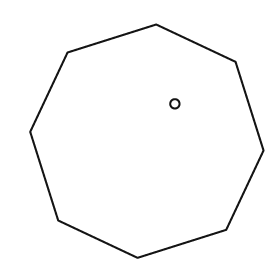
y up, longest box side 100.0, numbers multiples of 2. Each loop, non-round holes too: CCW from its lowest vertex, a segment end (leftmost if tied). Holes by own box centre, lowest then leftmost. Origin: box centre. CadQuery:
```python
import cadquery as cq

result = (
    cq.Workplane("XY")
    .moveTo(-4.0, -50.0)
    .lineTo(34.0, -38.0)
    .lineTo(50.0, -4.0)
    .lineTo(38.0, 34.0)
    .lineTo(4.0, 50.0)
    .lineTo(-34.0, 38.0)
    .lineTo(-50.0, 4.0)
    .lineTo(-38.0, -34.0)
    .close()
    .moveTo(12.0, 16.0)
    .circle(2.0)
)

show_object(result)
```